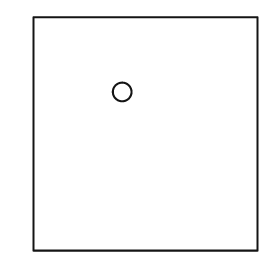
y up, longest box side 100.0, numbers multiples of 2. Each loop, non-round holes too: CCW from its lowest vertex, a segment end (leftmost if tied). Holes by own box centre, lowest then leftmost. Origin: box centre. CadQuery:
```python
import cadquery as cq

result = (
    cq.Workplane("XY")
    .moveTo(-48.0, -50.0)
    .lineTo(48.0, -50.0)
    .lineTo(48.0, 50.0)
    .lineTo(-48.0, 50.0)
    .close()
    .moveTo(-10.0, 18.0)
    .circle(4.0)
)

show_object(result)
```